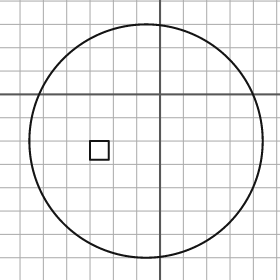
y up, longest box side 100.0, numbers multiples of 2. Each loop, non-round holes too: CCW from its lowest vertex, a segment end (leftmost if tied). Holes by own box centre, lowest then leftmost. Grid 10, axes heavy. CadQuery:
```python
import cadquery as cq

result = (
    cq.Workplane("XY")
    .moveTo(-6.0, -20.0)
    .circle(50.0)
    .moveTo(-30.0, -28.0)
    .lineTo(-22.0, -28.0)
    .lineTo(-22.0, -20.0)
    .lineTo(-30.0, -20.0)
    .close()
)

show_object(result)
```